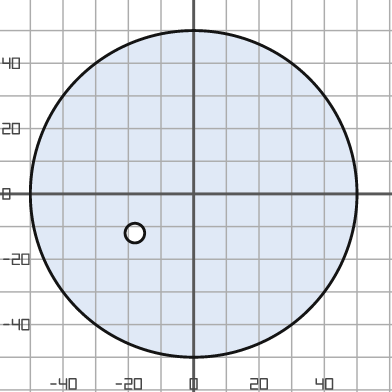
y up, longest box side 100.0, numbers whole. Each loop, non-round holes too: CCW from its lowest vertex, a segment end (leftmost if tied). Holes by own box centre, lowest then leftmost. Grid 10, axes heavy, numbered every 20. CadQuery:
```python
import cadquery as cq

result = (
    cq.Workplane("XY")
    .moveTo(0.0, 0.0)
    .circle(50.0)
    .moveTo(-18.0, -12.0)
    .circle(3.0)
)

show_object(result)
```